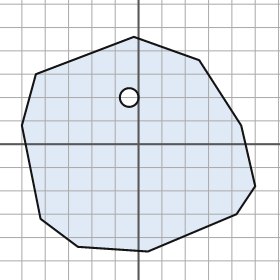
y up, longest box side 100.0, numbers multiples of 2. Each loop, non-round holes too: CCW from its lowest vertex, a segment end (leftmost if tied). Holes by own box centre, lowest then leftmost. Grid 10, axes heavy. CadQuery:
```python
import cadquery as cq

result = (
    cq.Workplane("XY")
    .moveTo(4.0, -46.0)
    .lineTo(42.0, -30.0)
    .lineTo(50.0, -18.0)
    .lineTo(44.0, 8.0)
    .lineTo(26.0, 36.0)
    .lineTo(-2.0, 46.0)
    .lineTo(-44.0, 30.0)
    .lineTo(-50.0, 8.0)
    .lineTo(-42.0, -32.0)
    .lineTo(-26.0, -44.0)
    .close()
    .moveTo(-4.0, 20.0)
    .circle(4.0)
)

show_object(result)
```